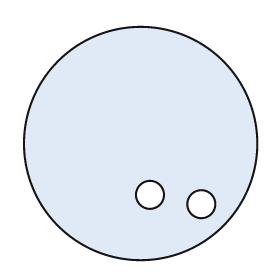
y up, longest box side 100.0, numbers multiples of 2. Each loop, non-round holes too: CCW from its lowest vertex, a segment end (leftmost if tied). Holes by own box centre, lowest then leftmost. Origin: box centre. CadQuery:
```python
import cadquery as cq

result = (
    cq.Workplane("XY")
    .moveTo(0.0, 0.0)
    .circle(50.0)
    .moveTo(26.0, -26.0)
    .circle(6.0)
    .moveTo(4.0, -22.0)
    .circle(6.0)
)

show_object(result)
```